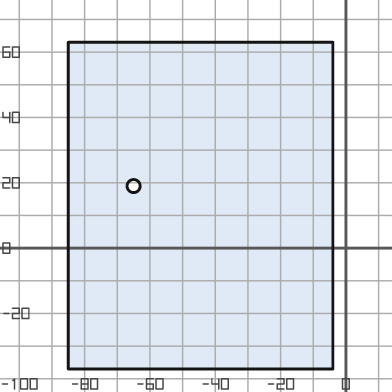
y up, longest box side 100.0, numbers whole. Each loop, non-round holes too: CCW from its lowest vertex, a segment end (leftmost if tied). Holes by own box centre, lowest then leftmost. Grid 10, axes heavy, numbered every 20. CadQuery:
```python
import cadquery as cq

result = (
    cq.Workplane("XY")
    .moveTo(-85.0, -37.0)
    .lineTo(-4.0, -37.0)
    .lineTo(-4.0, 63.0)
    .lineTo(-85.0, 63.0)
    .close()
    .moveTo(-65.0, 19.0)
    .circle(2.0)
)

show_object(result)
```